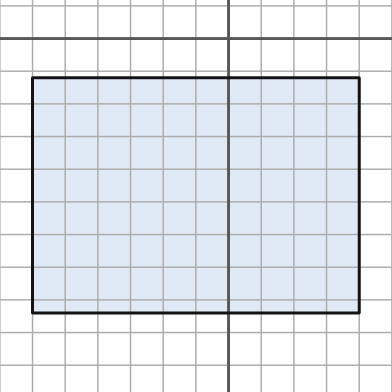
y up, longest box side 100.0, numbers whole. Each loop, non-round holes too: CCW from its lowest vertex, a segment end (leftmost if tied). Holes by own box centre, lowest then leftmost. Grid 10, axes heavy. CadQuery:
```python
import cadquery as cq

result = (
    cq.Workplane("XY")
    .moveTo(-60.0, -84.0)
    .lineTo(40.0, -84.0)
    .lineTo(40.0, -12.0)
    .lineTo(-60.0, -12.0)
    .close()
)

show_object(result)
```